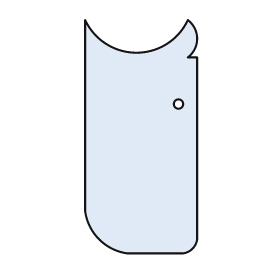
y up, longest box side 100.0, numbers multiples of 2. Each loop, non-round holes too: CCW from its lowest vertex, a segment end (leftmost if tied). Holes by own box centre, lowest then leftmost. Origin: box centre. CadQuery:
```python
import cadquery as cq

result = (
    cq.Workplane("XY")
    .moveTo(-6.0, -50.0)
    .lineTo(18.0, -50.0)
    .threePointArc((22.0, -48.0), (24.0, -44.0))
    .lineTo(24.0, 34.0)
    .lineTo(20.0, 34.0)
    .threePointArc((24.0, 42.0), (20.0, 50.0))
    .threePointArc((-2.0, 36.0), (-24.0, 50.0))
    .lineTo(-24.0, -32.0)
    .threePointArc((-18.0, -44.0), (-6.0, -50.0))
    .close()
    .moveTo(16.0, 14.0)
    .circle(2.0)
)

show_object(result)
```